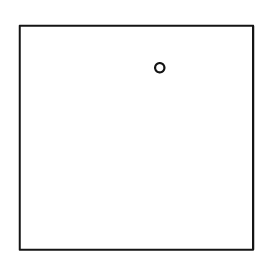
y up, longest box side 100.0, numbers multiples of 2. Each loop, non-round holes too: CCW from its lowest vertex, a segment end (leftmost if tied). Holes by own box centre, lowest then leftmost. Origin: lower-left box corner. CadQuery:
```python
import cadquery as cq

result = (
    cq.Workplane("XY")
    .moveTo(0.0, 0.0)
    .lineTo(100.0, 0.0)
    .lineTo(100.0, 96.0)
    .lineTo(0.0, 96.0)
    .close()
    .moveTo(60.0, 78.0)
    .circle(2.0)
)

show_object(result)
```